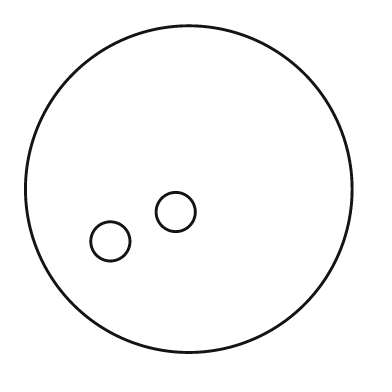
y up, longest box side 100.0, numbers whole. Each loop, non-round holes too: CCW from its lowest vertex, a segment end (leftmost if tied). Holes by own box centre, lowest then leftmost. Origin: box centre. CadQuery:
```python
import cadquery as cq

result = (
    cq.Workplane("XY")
    .moveTo(0.0, 0.0)
    .circle(50.0)
    .moveTo(-24.0, -16.0)
    .circle(6.0)
    .moveTo(-4.0, -7.0)
    .circle(6.0)
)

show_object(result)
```